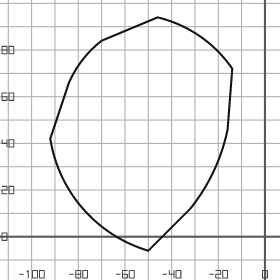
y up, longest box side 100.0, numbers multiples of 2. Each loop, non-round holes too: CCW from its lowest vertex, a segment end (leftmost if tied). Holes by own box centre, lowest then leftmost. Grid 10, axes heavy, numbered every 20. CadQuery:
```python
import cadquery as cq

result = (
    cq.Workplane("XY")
    .moveTo(-50.0, -6.0)
    .lineTo(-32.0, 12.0)
    .threePointArc((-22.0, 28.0), (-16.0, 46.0))
    .lineTo(-14.0, 72.0)
    .threePointArc((-28.0, 86.0), (-46.0, 94.0))
    .lineTo(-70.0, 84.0)
    .threePointArc((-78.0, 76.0), (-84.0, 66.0))
    .lineTo(-92.0, 42.0)
    .threePointArc((-78.0, 12.0), (-50.0, -6.0))
    .close()
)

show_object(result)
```